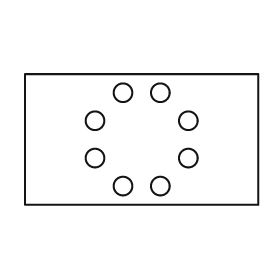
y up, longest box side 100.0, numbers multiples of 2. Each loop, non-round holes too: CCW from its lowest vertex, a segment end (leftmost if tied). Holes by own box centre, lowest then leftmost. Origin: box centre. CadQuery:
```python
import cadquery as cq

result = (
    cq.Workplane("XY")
    .moveTo(-50.0, -28.0)
    .lineTo(50.0, -28.0)
    .lineTo(50.0, 28.0)
    .lineTo(-50.0, 28.0)
    .close()
    .moveTo(-8.0, -20.0)
    .circle(4.0)
    .moveTo(8.0, -20.0)
    .circle(4.0)
    .moveTo(-20.0, -8.0)
    .circle(4.0)
    .moveTo(20.0, -8.0)
    .circle(4.0)
    .moveTo(-20.0, 8.0)
    .circle(4.0)
    .moveTo(20.0, 8.0)
    .circle(4.0)
    .moveTo(-8.0, 20.0)
    .circle(4.0)
    .moveTo(8.0, 20.0)
    .circle(4.0)
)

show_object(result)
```